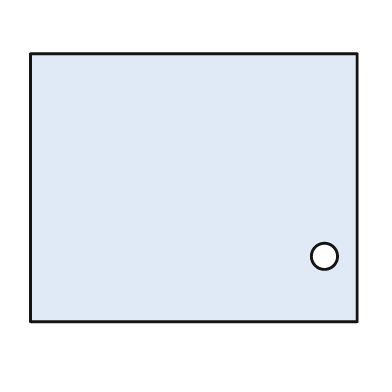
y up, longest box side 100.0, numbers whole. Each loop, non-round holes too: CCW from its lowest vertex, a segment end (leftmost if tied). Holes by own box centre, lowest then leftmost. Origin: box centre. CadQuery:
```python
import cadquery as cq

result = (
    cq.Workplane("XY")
    .moveTo(-50.0, -41.0)
    .lineTo(50.0, -41.0)
    .lineTo(50.0, 41.0)
    .lineTo(-50.0, 41.0)
    .close()
    .moveTo(40.0, -21.0)
    .circle(4.0)
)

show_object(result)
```